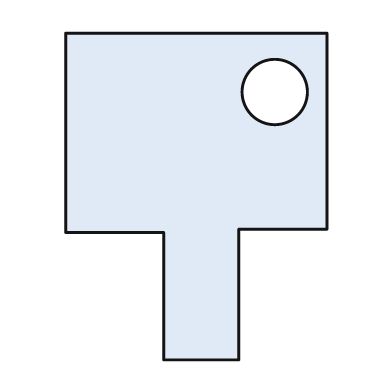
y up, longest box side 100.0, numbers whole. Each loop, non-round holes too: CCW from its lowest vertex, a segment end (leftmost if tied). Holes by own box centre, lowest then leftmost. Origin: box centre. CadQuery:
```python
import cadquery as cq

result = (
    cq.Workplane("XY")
    .moveTo(-10.0, -50.0)
    .lineTo(13.0, -50.0)
    .lineTo(13.0, -10.0)
    .lineTo(40.0, -10.0)
    .lineTo(40.0, 50.0)
    .lineTo(-40.0, 50.0)
    .lineTo(-40.0, -11.0)
    .lineTo(-10.0, -11.0)
    .close()
    .moveTo(24.0, 32.0)
    .circle(10.0)
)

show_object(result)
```